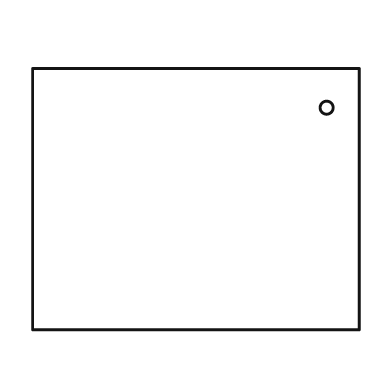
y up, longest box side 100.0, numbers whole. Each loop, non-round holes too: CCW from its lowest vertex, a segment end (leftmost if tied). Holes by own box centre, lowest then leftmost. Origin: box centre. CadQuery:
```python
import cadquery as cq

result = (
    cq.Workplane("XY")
    .moveTo(-50.0, -40.0)
    .lineTo(50.0, -40.0)
    .lineTo(50.0, 40.0)
    .lineTo(-50.0, 40.0)
    .close()
    .moveTo(40.0, 28.0)
    .circle(2.0)
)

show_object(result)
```